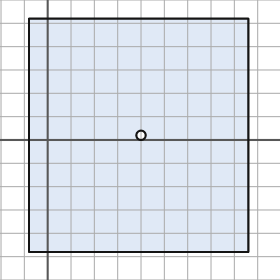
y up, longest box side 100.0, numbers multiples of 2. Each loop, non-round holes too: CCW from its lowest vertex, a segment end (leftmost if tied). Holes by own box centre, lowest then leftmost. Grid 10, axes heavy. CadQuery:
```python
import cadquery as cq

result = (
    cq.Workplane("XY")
    .moveTo(-8.0, -48.0)
    .lineTo(86.0, -48.0)
    .lineTo(86.0, 52.0)
    .lineTo(-8.0, 52.0)
    .close()
    .moveTo(40.0, 2.0)
    .circle(2.0)
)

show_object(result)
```